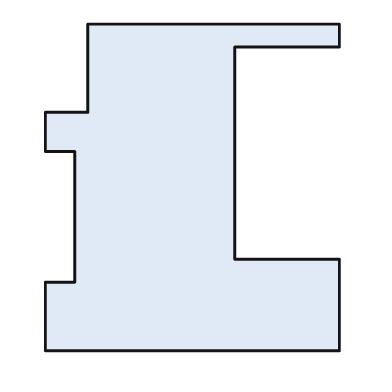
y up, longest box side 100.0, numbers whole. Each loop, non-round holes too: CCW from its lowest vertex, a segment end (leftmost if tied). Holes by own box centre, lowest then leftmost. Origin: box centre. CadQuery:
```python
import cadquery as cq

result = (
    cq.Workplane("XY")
    .moveTo(-45.0, -50.0)
    .lineTo(45.0, -50.0)
    .lineTo(45.0, -22.0)
    .lineTo(13.0, -22.0)
    .lineTo(13.0, 43.0)
    .lineTo(45.0, 43.0)
    .lineTo(45.0, 50.0)
    .lineTo(-32.0, 50.0)
    .lineTo(-32.0, 23.0)
    .lineTo(-45.0, 23.0)
    .lineTo(-45.0, 11.0)
    .lineTo(-36.0, 11.0)
    .lineTo(-36.0, -29.0)
    .lineTo(-45.0, -29.0)
    .close()
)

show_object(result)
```